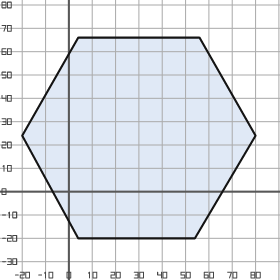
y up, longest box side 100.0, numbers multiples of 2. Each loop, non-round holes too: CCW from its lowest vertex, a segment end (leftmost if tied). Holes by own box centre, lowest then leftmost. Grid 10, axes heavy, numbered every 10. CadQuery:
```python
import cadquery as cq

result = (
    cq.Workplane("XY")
    .moveTo(4.0, -20.0)
    .lineTo(54.0, -20.0)
    .lineTo(80.0, 24.0)
    .lineTo(56.0, 66.0)
    .lineTo(4.0, 66.0)
    .lineTo(-20.0, 24.0)
    .close()
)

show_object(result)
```